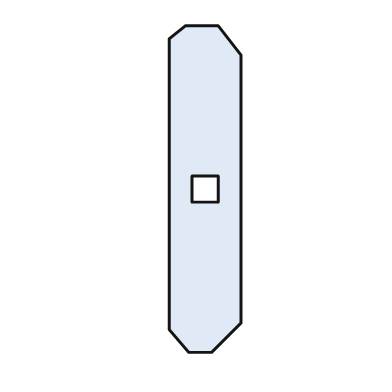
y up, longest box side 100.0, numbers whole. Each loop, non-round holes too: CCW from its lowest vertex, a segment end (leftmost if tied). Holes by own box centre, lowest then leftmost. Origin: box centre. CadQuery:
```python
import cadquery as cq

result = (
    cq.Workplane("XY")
    .moveTo(-5.0, -50.0)
    .lineTo(2.0, -50.0)
    .lineTo(11.0, -41.0)
    .lineTo(11.0, 41.0)
    .lineTo(4.0, 50.0)
    .lineTo(-6.0, 50.0)
    .lineTo(-11.0, 46.0)
    .lineTo(-11.0, -43.0)
    .close()
    .moveTo(-4.0, -4.0)
    .lineTo(4.0, -4.0)
    .lineTo(4.0, 4.0)
    .lineTo(-4.0, 4.0)
    .close()
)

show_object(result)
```